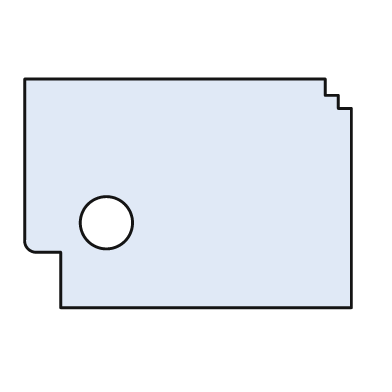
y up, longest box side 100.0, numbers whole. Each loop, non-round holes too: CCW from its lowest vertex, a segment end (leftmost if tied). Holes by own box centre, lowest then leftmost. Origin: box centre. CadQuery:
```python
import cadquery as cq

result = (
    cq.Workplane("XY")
    .moveTo(-39.0, -35.0)
    .lineTo(50.0, -35.0)
    .lineTo(50.0, 26.0)
    .lineTo(46.0, 26.0)
    .lineTo(46.0, 30.0)
    .lineTo(42.0, 30.0)
    .lineTo(42.0, 35.0)
    .lineTo(-50.0, 35.0)
    .lineTo(-50.0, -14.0)
    .threePointArc((-49.0, -17.0), (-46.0, -18.0))
    .lineTo(-39.0, -18.0)
    .close()
    .moveTo(-25.0, -9.0)
    .circle(8.0)
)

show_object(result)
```